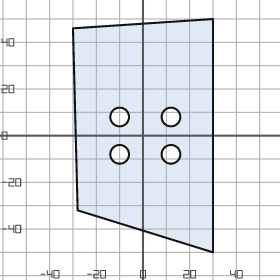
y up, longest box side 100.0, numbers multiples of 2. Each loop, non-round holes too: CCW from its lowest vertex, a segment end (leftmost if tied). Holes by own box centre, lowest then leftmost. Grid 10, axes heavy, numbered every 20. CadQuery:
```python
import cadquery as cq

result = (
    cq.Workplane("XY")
    .moveTo(30.0, -50.0)
    .lineTo(30.0, 50.0)
    .lineTo(-30.0, 46.0)
    .lineTo(-28.0, -32.0)
    .close()
    .moveTo(-10.0, -8.0)
    .circle(4.0)
    .moveTo(12.0, -8.0)
    .circle(4.0)
    .moveTo(-10.0, 8.0)
    .circle(4.0)
    .moveTo(12.0, 8.0)
    .circle(4.0)
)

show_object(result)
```